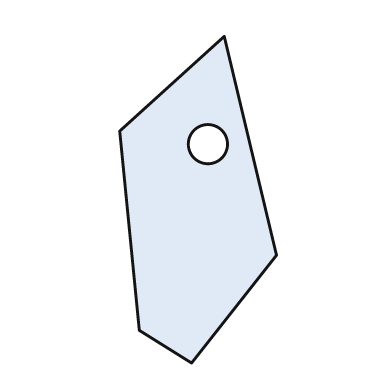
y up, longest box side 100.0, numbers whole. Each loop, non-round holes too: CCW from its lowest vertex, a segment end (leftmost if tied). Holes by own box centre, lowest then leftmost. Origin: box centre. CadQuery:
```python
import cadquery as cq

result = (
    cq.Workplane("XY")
    .moveTo(-2.0, -50.0)
    .lineTo(24.0, -17.0)
    .lineTo(8.0, 50.0)
    .lineTo(-24.0, 21.0)
    .lineTo(-18.0, -40.0)
    .close()
    .moveTo(3.0, 17.0)
    .circle(6.0)
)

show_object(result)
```